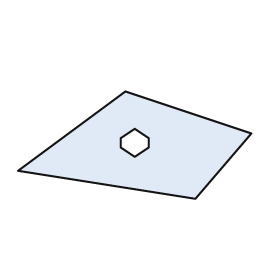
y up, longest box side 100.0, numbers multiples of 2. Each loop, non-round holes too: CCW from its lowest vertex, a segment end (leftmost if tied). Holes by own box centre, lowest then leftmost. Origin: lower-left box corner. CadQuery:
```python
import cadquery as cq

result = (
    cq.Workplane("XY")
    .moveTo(76.0, 0.0)
    .lineTo(100.0, 28.0)
    .lineTo(46.0, 46.0)
    .lineTo(0.0, 12.0)
    .close()
    .moveTo(50.0, 18.0)
    .lineTo(56.0, 22.0)
    .lineTo(56.0, 26.0)
    .lineTo(50.0, 30.0)
    .lineTo(44.0, 26.0)
    .lineTo(44.0, 22.0)
    .close()
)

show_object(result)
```